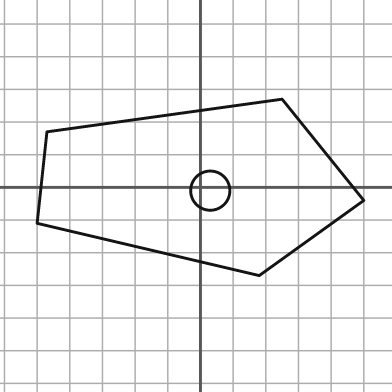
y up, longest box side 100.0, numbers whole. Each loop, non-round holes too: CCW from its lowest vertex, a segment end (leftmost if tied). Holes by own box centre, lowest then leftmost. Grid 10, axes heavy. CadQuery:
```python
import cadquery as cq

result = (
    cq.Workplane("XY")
    .moveTo(18.0, -27.0)
    .lineTo(50.0, -4.0)
    .lineTo(25.0, 27.0)
    .lineTo(-47.0, 17.0)
    .lineTo(-50.0, -11.0)
    .close()
    .moveTo(3.0, -1.0)
    .circle(6.0)
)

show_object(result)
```